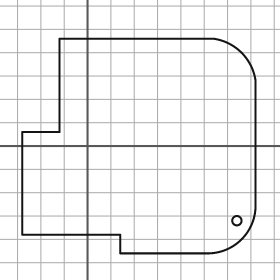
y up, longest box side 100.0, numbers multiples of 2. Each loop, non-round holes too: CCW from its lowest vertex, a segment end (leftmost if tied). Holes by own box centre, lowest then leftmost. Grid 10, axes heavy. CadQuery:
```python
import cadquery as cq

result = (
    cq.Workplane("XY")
    .moveTo(14.0, -46.0)
    .lineTo(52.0, -46.0)
    .threePointArc((66.0, -40.0), (72.0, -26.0))
    .lineTo(72.0, 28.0)
    .threePointArc((66.0, 40.0), (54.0, 46.0))
    .lineTo(-12.0, 46.0)
    .lineTo(-12.0, 6.0)
    .lineTo(-28.0, 6.0)
    .lineTo(-28.0, -38.0)
    .lineTo(14.0, -38.0)
    .close()
    .moveTo(64.0, -32.0)
    .circle(2.0)
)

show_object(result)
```